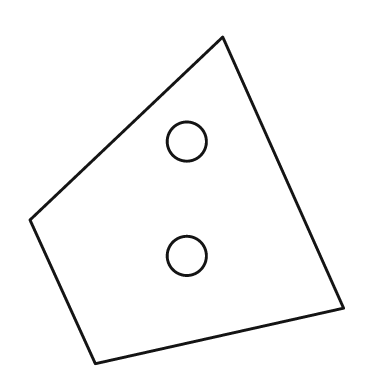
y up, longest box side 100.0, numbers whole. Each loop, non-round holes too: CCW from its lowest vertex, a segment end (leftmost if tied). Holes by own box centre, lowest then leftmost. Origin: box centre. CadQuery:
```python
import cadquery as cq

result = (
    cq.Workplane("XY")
    .moveTo(-28.0, -50.0)
    .lineTo(48.0, -33.0)
    .lineTo(11.0, 50.0)
    .lineTo(-48.0, -6.0)
    .close()
    .moveTo(0.0, -17.0)
    .circle(6.0)
    .moveTo(0.0, 18.0)
    .circle(6.0)
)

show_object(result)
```